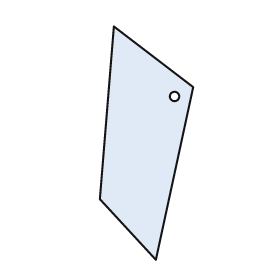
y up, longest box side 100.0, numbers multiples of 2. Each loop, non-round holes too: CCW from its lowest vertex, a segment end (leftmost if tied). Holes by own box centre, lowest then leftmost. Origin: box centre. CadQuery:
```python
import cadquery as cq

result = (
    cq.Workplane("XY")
    .moveTo(4.0, -50.0)
    .lineTo(20.0, 24.0)
    .lineTo(-14.0, 50.0)
    .lineTo(-20.0, -24.0)
    .close()
    .moveTo(12.0, 20.0)
    .circle(2.0)
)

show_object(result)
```